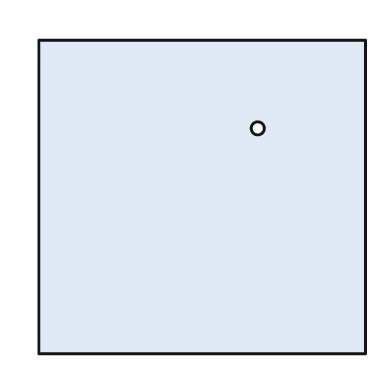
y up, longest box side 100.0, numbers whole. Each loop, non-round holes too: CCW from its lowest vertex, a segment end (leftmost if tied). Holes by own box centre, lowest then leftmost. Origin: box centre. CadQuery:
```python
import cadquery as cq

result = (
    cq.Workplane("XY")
    .moveTo(-50.0, -48.0)
    .lineTo(50.0, -48.0)
    .lineTo(50.0, 48.0)
    .lineTo(-50.0, 48.0)
    .close()
    .moveTo(17.0, 21.0)
    .circle(2.0)
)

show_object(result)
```